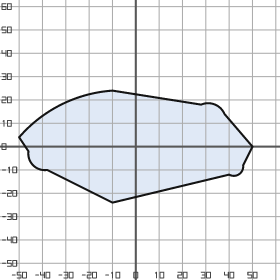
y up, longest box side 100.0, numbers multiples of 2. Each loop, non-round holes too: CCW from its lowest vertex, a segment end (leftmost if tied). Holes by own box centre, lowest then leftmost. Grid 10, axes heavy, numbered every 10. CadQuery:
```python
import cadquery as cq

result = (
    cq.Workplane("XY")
    .moveTo(-10.0, -24.0)
    .lineTo(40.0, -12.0)
    .threePointArc((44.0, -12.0), (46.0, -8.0))
    .lineTo(50.0, 0.0)
    .lineTo(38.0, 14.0)
    .threePointArc((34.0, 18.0), (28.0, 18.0))
    .lineTo(-10.0, 24.0)
    .threePointArc((-32.0, 18.0), (-50.0, 4.0))
    .lineTo(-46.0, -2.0)
    .threePointArc((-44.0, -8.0), (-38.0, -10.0))
    .close()
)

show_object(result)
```